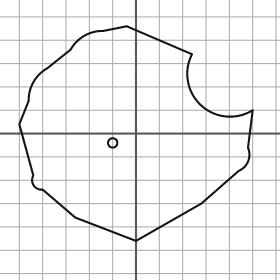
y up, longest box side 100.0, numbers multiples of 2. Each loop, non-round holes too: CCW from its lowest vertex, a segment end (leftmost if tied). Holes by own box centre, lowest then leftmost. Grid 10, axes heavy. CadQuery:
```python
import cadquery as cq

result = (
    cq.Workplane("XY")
    .moveTo(0.0, -46.0)
    .lineTo(28.0, -30.0)
    .lineTo(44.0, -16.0)
    .threePointArc((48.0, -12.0), (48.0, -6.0))
    .lineTo(50.0, 10.0)
    .threePointArc((28.0, 12.0), (24.0, 34.0))
    .lineTo(-4.0, 46.0)
    .lineTo(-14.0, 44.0)
    .threePointArc((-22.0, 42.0), (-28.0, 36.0))
    .lineTo(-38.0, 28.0)
    .threePointArc((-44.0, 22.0), (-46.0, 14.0))
    .lineTo(-50.0, 4.0)
    .lineTo(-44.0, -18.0)
    .threePointArc((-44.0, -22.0), (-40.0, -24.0))
    .lineTo(-26.0, -36.0)
    .close()
    .moveTo(-10.0, -4.0)
    .circle(2.0)
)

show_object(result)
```